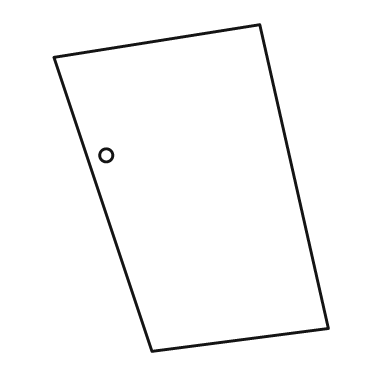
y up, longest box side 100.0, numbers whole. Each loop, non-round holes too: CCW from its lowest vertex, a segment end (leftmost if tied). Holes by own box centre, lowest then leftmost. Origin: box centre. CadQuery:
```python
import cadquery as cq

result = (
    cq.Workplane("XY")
    .moveTo(-12.0, -50.0)
    .lineTo(42.0, -43.0)
    .lineTo(21.0, 50.0)
    .lineTo(-42.0, 40.0)
    .close()
    .moveTo(-26.0, 10.0)
    .circle(2.0)
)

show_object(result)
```